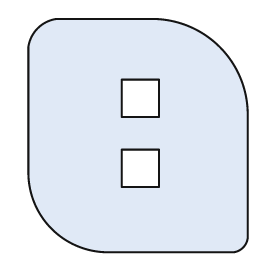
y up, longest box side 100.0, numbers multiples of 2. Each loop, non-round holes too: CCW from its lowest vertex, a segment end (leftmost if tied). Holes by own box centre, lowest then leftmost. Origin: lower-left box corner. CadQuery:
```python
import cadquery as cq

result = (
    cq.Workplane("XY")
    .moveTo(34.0, 0.0)
    .lineTo(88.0, 0.0)
    .threePointArc((92.0, 2.0), (94.0, 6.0))
    .lineTo(94.0, 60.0)
    .threePointArc((82.0, 88.0), (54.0, 100.0))
    .lineTo(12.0, 100.0)
    .threePointArc((4.0, 96.0), (0.0, 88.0))
    .lineTo(0.0, 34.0)
    .threePointArc((10.0, 10.0), (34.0, 0.0))
    .close()
    .moveTo(40.0, 28.0)
    .lineTo(56.0, 28.0)
    .lineTo(56.0, 44.0)
    .lineTo(40.0, 44.0)
    .close()
    .moveTo(40.0, 58.0)
    .lineTo(56.0, 58.0)
    .lineTo(56.0, 74.0)
    .lineTo(40.0, 74.0)
    .close()
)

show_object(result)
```